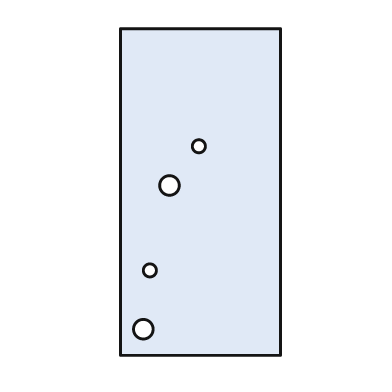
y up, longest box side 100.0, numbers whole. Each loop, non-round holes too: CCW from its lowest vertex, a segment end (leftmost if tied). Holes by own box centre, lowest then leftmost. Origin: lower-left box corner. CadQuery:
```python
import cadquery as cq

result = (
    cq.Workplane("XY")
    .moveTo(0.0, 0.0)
    .lineTo(49.0, 0.0)
    .lineTo(49.0, 100.0)
    .lineTo(0.0, 100.0)
    .close()
    .moveTo(7.0, 8.0)
    .circle(3.0)
    .moveTo(9.0, 26.0)
    .circle(2.0)
    .moveTo(15.0, 52.0)
    .circle(3.0)
    .moveTo(24.0, 64.0)
    .circle(2.0)
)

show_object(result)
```